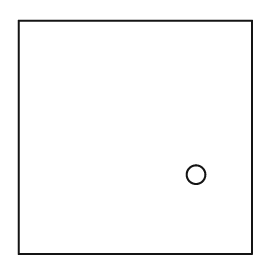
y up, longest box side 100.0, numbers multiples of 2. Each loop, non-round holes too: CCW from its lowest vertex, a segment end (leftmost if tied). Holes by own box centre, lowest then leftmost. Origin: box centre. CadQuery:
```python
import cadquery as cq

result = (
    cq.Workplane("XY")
    .moveTo(-50.0, -50.0)
    .lineTo(50.0, -50.0)
    .lineTo(50.0, 50.0)
    .lineTo(-50.0, 50.0)
    .close()
    .moveTo(26.0, -16.0)
    .circle(4.0)
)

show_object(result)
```